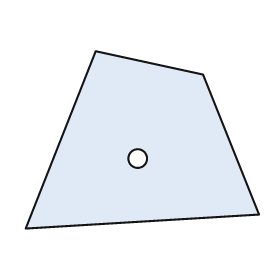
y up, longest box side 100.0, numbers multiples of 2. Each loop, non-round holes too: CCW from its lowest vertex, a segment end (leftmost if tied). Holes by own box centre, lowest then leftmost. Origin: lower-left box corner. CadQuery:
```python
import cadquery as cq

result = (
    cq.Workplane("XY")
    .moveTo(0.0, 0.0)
    .lineTo(100.0, 6.0)
    .lineTo(76.0, 66.0)
    .lineTo(30.0, 76.0)
    .close()
    .moveTo(48.0, 30.0)
    .circle(4.0)
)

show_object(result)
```